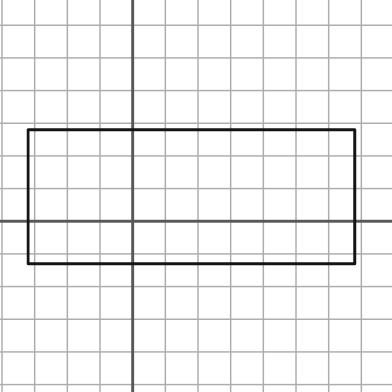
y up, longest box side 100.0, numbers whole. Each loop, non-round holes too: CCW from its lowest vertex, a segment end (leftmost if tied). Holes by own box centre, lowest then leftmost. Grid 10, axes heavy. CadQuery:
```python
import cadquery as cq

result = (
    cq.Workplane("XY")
    .moveTo(-32.0, -13.0)
    .lineTo(68.0, -13.0)
    .lineTo(68.0, 28.0)
    .lineTo(-32.0, 28.0)
    .close()
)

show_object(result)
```